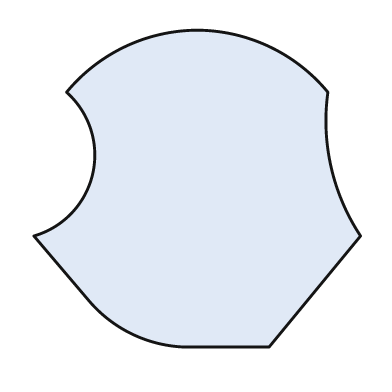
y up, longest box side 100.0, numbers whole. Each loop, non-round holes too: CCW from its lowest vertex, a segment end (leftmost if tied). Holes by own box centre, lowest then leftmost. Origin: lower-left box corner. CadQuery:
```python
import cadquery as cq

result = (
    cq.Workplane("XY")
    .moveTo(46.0, 0.0)
    .lineTo(72.0, 0.0)
    .lineTo(100.0, 34.0)
    .threePointArc((91.0, 55.0), (90.0, 78.0))
    .threePointArc((72.0, 92.0), (50.0, 97.0))
    .threePointArc((28.0, 92.0), (10.0, 78.0))
    .threePointArc((18.0, 53.0), (0.0, 34.0))
    .lineTo(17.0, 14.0)
    .threePointArc((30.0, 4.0), (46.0, 0.0))
    .close()
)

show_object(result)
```